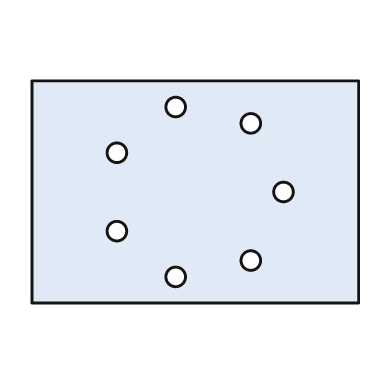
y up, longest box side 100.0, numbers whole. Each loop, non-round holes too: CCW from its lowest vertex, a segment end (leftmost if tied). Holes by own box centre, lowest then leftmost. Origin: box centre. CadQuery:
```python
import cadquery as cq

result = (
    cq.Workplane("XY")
    .moveTo(-50.0, -34.0)
    .lineTo(50.0, -34.0)
    .lineTo(50.0, 34.0)
    .lineTo(-50.0, 34.0)
    .close()
    .moveTo(-6.0, -26.0)
    .circle(3.0)
    .moveTo(17.0, -21.0)
    .circle(3.0)
    .moveTo(-24.0, -12.0)
    .circle(3.0)
    .moveTo(27.0, 0.0)
    .circle(3.0)
    .moveTo(-24.0, 12.0)
    .circle(3.0)
    .moveTo(17.0, 21.0)
    .circle(3.0)
    .moveTo(-6.0, 26.0)
    .circle(3.0)
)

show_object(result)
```